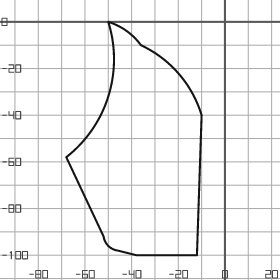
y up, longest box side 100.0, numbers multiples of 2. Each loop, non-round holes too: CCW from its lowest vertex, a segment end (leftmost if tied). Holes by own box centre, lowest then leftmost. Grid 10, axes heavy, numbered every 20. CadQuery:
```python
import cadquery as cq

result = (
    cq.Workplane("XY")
    .moveTo(-38.0, -100.0)
    .lineTo(-12.0, -100.0)
    .lineTo(-10.0, -40.0)
    .threePointArc((-20.0, -22.0), (-36.0, -10.0))
    .threePointArc((-42.0, -4.0), (-50.0, 0.0))
    .threePointArc((-50.0, -32.0), (-68.0, -58.0))
    .lineTo(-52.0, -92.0)
    .threePointArc((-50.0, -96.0), (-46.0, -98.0))
    .close()
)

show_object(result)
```